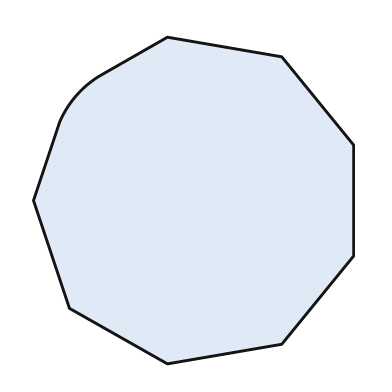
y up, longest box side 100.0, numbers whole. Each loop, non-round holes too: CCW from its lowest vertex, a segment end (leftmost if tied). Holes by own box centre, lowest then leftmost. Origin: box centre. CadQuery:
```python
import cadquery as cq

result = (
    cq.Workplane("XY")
    .moveTo(-8.0, -50.0)
    .lineTo(27.0, -44.0)
    .lineTo(49.0, -17.0)
    .lineTo(49.0, 17.0)
    .lineTo(27.0, 44.0)
    .lineTo(-8.0, 50.0)
    .lineTo(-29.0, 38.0)
    .threePointArc((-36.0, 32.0), (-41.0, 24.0))
    .lineTo(-49.0, 0.0)
    .lineTo(-38.0, -33.0)
    .close()
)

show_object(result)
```